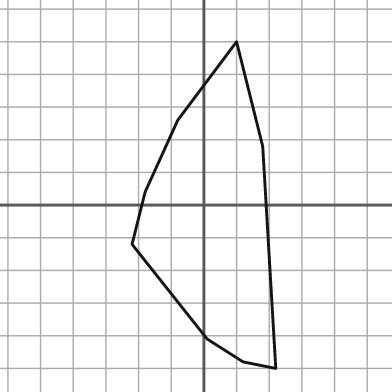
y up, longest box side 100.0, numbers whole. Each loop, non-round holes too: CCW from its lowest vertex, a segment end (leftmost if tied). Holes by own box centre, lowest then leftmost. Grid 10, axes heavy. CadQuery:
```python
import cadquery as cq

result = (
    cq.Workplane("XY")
    .moveTo(22.0, -50.0)
    .lineTo(18.0, 18.0)
    .lineTo(10.0, 50.0)
    .lineTo(-8.0, 26.0)
    .lineTo(-18.0, 4.0)
    .lineTo(-22.0, -12.0)
    .lineTo(1.0, -41.0)
    .lineTo(12.0, -48.0)
    .close()
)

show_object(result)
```